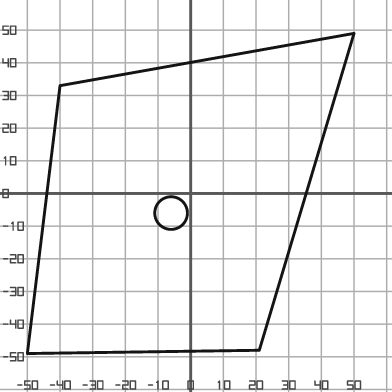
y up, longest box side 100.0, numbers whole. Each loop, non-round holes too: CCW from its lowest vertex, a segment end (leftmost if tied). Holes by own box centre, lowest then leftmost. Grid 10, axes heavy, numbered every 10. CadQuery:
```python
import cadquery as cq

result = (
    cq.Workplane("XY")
    .moveTo(-50.0, -49.0)
    .lineTo(21.0, -48.0)
    .lineTo(50.0, 49.0)
    .lineTo(-40.0, 33.0)
    .close()
    .moveTo(-6.0, -6.0)
    .circle(5.0)
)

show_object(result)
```